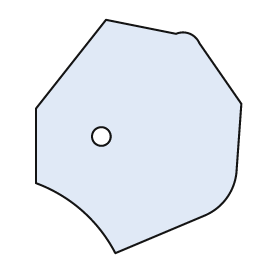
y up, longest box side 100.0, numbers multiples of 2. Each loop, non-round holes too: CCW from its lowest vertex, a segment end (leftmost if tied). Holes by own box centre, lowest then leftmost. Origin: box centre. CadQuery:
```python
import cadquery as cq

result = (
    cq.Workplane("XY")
    .moveTo(-10.0, -50.0)
    .lineTo(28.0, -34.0)
    .threePointArc((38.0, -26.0), (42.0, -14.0))
    .lineTo(44.0, 14.0)
    .lineTo(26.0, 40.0)
    .threePointArc((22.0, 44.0), (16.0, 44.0))
    .lineTo(-14.0, 50.0)
    .lineTo(-44.0, 12.0)
    .lineTo(-44.0, -20.0)
    .threePointArc((-24.0, -32.0), (-10.0, -50.0))
    .close()
    .moveTo(-16.0, 0.0)
    .circle(4.0)
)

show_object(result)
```